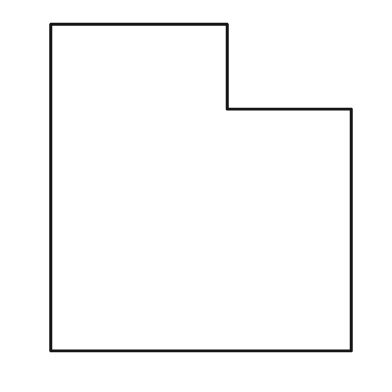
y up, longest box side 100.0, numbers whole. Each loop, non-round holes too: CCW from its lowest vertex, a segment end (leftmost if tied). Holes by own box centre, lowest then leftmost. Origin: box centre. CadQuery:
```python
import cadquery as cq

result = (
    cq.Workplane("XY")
    .moveTo(-46.0, -50.0)
    .lineTo(46.0, -50.0)
    .lineTo(46.0, 24.0)
    .lineTo(8.0, 24.0)
    .lineTo(8.0, 50.0)
    .lineTo(-46.0, 50.0)
    .close()
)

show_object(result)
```